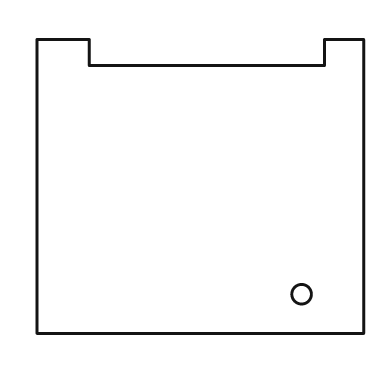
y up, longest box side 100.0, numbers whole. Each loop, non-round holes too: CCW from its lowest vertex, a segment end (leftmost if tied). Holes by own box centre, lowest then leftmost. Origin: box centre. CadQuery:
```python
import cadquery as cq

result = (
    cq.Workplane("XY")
    .moveTo(-50.0, -45.0)
    .lineTo(50.0, -45.0)
    .lineTo(50.0, 45.0)
    .lineTo(38.0, 45.0)
    .lineTo(38.0, 37.0)
    .lineTo(-34.0, 37.0)
    .lineTo(-34.0, 45.0)
    .lineTo(-50.0, 45.0)
    .close()
    .moveTo(31.0, -33.0)
    .circle(3.0)
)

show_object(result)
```